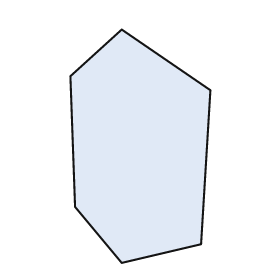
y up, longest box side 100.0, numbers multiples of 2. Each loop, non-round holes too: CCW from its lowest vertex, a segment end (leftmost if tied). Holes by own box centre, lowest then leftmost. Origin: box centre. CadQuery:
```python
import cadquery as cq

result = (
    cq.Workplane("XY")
    .moveTo(-8.0, -50.0)
    .lineTo(26.0, -42.0)
    .lineTo(30.0, 24.0)
    .lineTo(-8.0, 50.0)
    .lineTo(-30.0, 30.0)
    .lineTo(-28.0, -26.0)
    .close()
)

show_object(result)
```